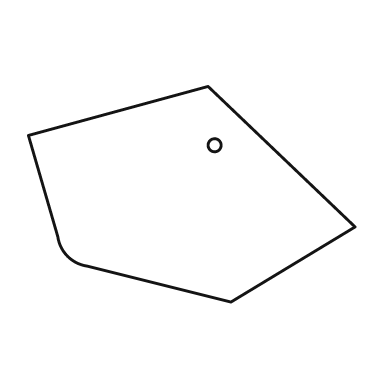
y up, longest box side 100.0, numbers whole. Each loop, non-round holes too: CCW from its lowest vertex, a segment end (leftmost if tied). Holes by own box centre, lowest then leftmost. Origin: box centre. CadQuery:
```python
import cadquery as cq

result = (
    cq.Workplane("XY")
    .moveTo(12.0, -33.0)
    .lineTo(50.0, -10.0)
    .lineTo(5.0, 33.0)
    .lineTo(-50.0, 18.0)
    .lineTo(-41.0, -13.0)
    .threePointArc((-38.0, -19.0), (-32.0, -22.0))
    .close()
    .moveTo(7.0, 15.0)
    .circle(2.0)
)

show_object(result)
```